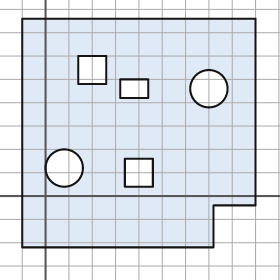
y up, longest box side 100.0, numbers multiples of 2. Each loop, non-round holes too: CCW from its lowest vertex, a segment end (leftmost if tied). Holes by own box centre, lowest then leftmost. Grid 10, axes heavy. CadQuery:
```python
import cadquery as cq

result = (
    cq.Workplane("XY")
    .moveTo(-10.0, -22.0)
    .lineTo(72.0, -22.0)
    .lineTo(72.0, -4.0)
    .lineTo(90.0, -4.0)
    .lineTo(90.0, 76.0)
    .lineTo(-10.0, 76.0)
    .close()
    .moveTo(34.0, 4.0)
    .lineTo(46.0, 4.0)
    .lineTo(46.0, 16.0)
    .lineTo(34.0, 16.0)
    .close()
    .moveTo(8.0, 12.0)
    .circle(8.0)
    .moveTo(32.0, 42.0)
    .lineTo(44.0, 42.0)
    .lineTo(44.0, 50.0)
    .lineTo(32.0, 50.0)
    .close()
    .moveTo(70.0, 46.0)
    .circle(8.0)
    .moveTo(14.0, 48.0)
    .lineTo(26.0, 48.0)
    .lineTo(26.0, 60.0)
    .lineTo(14.0, 60.0)
    .close()
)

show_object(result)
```